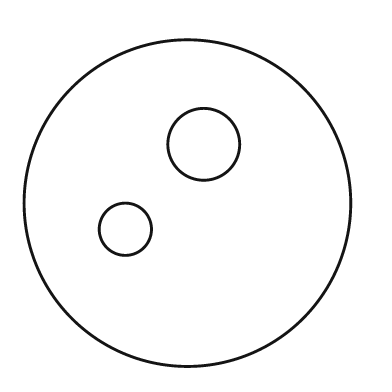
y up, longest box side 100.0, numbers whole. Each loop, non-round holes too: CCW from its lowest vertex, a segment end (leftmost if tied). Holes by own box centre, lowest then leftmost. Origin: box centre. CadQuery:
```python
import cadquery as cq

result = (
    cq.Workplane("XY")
    .moveTo(0.0, 0.0)
    .circle(50.0)
    .moveTo(-19.0, -8.0)
    .circle(8.0)
    .moveTo(5.0, 18.0)
    .circle(11.0)
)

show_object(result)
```